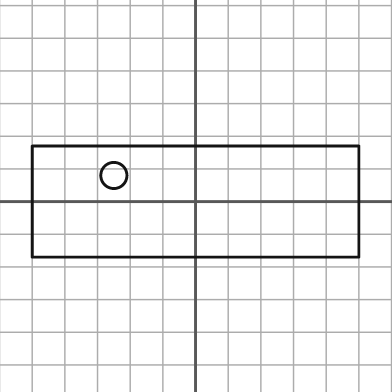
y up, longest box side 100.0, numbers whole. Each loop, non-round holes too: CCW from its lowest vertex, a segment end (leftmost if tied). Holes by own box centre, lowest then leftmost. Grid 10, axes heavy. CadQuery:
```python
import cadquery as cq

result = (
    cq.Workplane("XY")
    .moveTo(-50.0, -17.0)
    .lineTo(50.0, -17.0)
    .lineTo(50.0, 17.0)
    .lineTo(-50.0, 17.0)
    .close()
    .moveTo(-25.0, 8.0)
    .circle(4.0)
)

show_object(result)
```